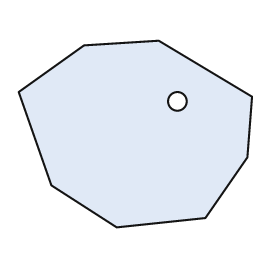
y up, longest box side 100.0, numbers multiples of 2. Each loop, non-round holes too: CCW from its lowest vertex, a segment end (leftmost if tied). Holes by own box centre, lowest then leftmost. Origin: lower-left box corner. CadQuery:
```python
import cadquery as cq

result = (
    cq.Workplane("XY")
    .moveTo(42.0, 0.0)
    .lineTo(80.0, 4.0)
    .lineTo(98.0, 30.0)
    .lineTo(100.0, 56.0)
    .lineTo(60.0, 80.0)
    .lineTo(28.0, 78.0)
    .lineTo(0.0, 58.0)
    .lineTo(14.0, 18.0)
    .close()
    .moveTo(68.0, 54.0)
    .circle(4.0)
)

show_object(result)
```